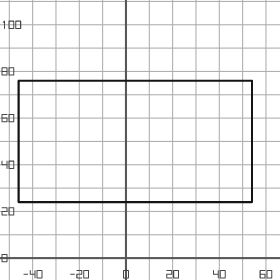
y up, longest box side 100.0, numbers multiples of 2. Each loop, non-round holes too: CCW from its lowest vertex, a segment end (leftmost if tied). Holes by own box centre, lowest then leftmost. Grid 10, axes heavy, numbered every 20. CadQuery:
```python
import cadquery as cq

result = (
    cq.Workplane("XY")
    .moveTo(-46.0, 24.0)
    .lineTo(54.0, 24.0)
    .lineTo(54.0, 76.0)
    .lineTo(-46.0, 76.0)
    .close()
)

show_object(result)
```